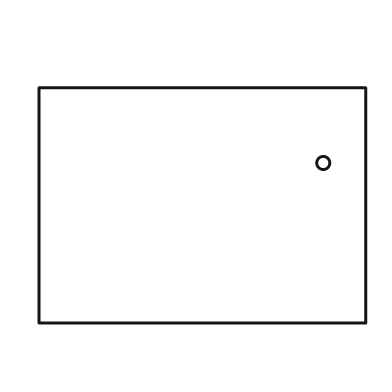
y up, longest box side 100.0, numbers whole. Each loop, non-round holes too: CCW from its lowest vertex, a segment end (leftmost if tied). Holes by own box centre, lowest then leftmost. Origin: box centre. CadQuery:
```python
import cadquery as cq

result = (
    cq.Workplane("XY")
    .moveTo(-50.0, -36.0)
    .lineTo(50.0, -36.0)
    .lineTo(50.0, 36.0)
    .lineTo(-50.0, 36.0)
    .close()
    .moveTo(37.0, 13.0)
    .circle(2.0)
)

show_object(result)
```